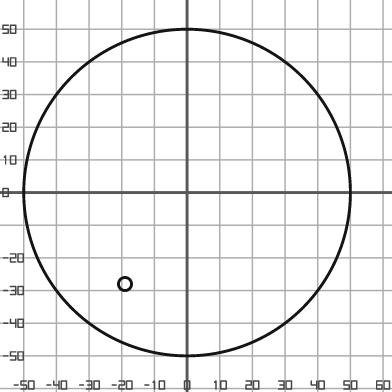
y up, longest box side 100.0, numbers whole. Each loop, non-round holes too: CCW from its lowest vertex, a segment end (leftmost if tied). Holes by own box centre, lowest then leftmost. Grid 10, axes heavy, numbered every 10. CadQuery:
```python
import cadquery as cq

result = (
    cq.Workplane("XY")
    .moveTo(0.0, 0.0)
    .circle(50.0)
    .moveTo(-19.0, -28.0)
    .circle(2.0)
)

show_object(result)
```